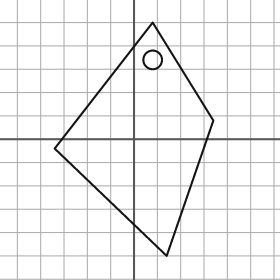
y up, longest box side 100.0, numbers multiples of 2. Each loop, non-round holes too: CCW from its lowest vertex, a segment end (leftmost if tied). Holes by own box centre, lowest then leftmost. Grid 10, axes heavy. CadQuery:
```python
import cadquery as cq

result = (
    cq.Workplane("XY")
    .moveTo(14.0, -50.0)
    .lineTo(34.0, 8.0)
    .lineTo(8.0, 50.0)
    .lineTo(-34.0, -4.0)
    .close()
    .moveTo(8.0, 34.0)
    .circle(4.0)
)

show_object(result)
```